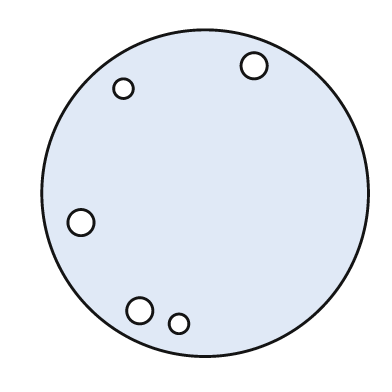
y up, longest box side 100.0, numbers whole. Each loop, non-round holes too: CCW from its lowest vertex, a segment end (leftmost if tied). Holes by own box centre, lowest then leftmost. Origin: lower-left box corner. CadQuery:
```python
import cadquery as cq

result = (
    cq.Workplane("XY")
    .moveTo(50.0, 50.0)
    .circle(50.0)
    .moveTo(42.0, 10.0)
    .circle(3.0)
    .moveTo(30.0, 14.0)
    .circle(4.0)
    .moveTo(12.0, 41.0)
    .circle(4.0)
    .moveTo(25.0, 82.0)
    .circle(3.0)
    .moveTo(65.0, 89.0)
    .circle(4.0)
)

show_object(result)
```